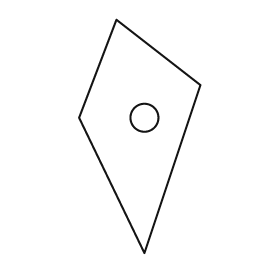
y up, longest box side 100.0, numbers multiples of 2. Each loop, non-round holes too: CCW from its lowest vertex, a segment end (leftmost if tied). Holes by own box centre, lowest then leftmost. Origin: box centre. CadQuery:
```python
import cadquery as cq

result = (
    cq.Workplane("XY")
    .moveTo(2.0, -50.0)
    .lineTo(26.0, 22.0)
    .lineTo(-10.0, 50.0)
    .lineTo(-26.0, 8.0)
    .close()
    .moveTo(2.0, 8.0)
    .circle(6.0)
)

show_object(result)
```